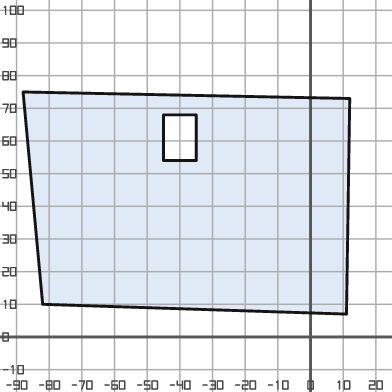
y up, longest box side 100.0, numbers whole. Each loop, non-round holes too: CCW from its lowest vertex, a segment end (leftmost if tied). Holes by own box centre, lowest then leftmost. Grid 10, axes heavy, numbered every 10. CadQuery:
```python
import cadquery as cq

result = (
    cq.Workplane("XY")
    .moveTo(11.0, 7.0)
    .lineTo(12.0, 73.0)
    .lineTo(-88.0, 75.0)
    .lineTo(-82.0, 10.0)
    .close()
    .moveTo(-45.0, 54.0)
    .lineTo(-35.0, 54.0)
    .lineTo(-35.0, 68.0)
    .lineTo(-45.0, 68.0)
    .close()
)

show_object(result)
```